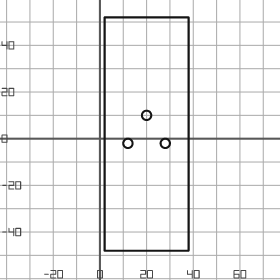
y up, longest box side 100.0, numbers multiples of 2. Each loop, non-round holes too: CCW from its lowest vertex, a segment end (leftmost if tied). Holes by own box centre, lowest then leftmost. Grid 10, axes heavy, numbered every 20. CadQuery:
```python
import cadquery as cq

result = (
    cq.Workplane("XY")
    .moveTo(2.0, -48.0)
    .lineTo(38.0, -48.0)
    .lineTo(38.0, 52.0)
    .lineTo(2.0, 52.0)
    .close()
    .moveTo(12.0, -2.0)
    .circle(2.0)
    .moveTo(28.0, -2.0)
    .circle(2.0)
    .moveTo(20.0, 10.0)
    .circle(2.0)
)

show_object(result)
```